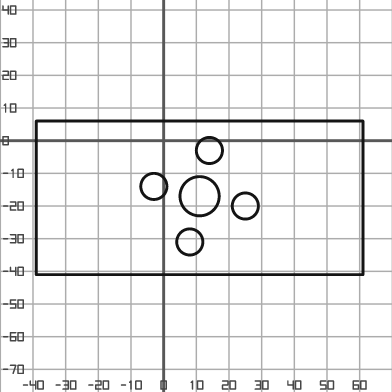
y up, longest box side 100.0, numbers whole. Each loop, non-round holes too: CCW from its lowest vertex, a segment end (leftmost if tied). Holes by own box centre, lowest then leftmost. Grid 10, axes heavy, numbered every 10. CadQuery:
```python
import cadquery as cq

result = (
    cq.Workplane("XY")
    .moveTo(-39.0, -41.0)
    .lineTo(61.0, -41.0)
    .lineTo(61.0, 6.0)
    .lineTo(-39.0, 6.0)
    .close()
    .moveTo(8.0, -31.0)
    .circle(4.0)
    .moveTo(25.0, -20.0)
    .circle(4.0)
    .moveTo(11.0, -17.0)
    .circle(6.0)
    .moveTo(-3.0, -14.0)
    .circle(4.0)
    .moveTo(14.0, -3.0)
    .circle(4.0)
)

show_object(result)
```